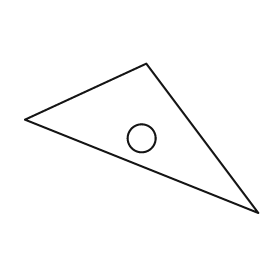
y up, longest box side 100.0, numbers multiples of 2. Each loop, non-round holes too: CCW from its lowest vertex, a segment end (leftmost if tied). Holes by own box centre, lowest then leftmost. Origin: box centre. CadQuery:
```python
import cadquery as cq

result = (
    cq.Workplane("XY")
    .moveTo(50.0, -32.0)
    .lineTo(2.0, 32.0)
    .lineTo(-50.0, 8.0)
    .close()
    .moveTo(0.0, 0.0)
    .circle(6.0)
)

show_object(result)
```